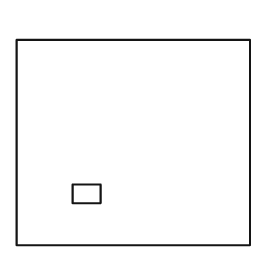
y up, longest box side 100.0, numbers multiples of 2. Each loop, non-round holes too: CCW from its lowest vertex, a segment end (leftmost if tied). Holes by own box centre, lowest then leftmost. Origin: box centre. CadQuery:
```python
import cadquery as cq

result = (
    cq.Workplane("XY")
    .moveTo(-50.0, -44.0)
    .lineTo(50.0, -44.0)
    .lineTo(50.0, 44.0)
    .lineTo(-50.0, 44.0)
    .close()
    .moveTo(-26.0, -26.0)
    .lineTo(-14.0, -26.0)
    .lineTo(-14.0, -18.0)
    .lineTo(-26.0, -18.0)
    .close()
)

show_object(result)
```